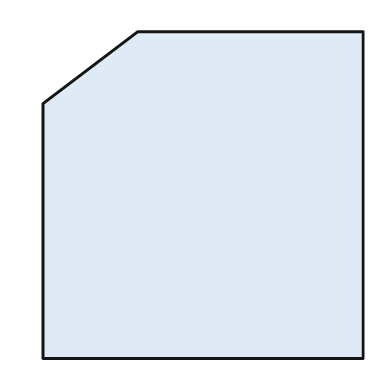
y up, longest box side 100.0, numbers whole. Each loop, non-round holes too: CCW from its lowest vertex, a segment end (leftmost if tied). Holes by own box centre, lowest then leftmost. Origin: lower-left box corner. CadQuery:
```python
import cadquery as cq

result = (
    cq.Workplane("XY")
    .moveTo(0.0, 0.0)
    .lineTo(98.0, 0.0)
    .lineTo(98.0, 100.0)
    .lineTo(29.0, 100.0)
    .lineTo(0.0, 78.0)
    .close()
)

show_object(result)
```